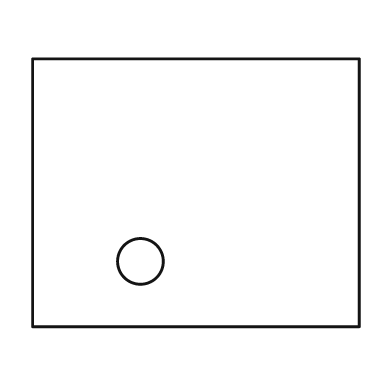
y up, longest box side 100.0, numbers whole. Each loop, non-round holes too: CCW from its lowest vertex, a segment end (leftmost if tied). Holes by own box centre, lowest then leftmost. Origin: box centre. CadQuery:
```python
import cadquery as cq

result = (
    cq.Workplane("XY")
    .moveTo(-50.0, -41.0)
    .lineTo(50.0, -41.0)
    .lineTo(50.0, 41.0)
    .lineTo(-50.0, 41.0)
    .close()
    .moveTo(-17.0, -21.0)
    .circle(7.0)
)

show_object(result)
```